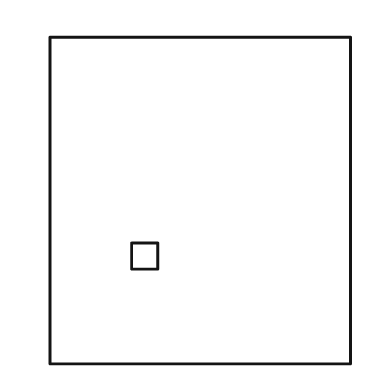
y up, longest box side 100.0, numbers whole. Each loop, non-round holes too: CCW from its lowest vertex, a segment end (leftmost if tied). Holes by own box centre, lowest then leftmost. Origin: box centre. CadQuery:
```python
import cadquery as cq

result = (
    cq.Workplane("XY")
    .moveTo(-46.0, -50.0)
    .lineTo(46.0, -50.0)
    .lineTo(46.0, 50.0)
    .lineTo(-46.0, 50.0)
    .close()
    .moveTo(-21.0, -21.0)
    .lineTo(-13.0, -21.0)
    .lineTo(-13.0, -13.0)
    .lineTo(-21.0, -13.0)
    .close()
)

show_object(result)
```